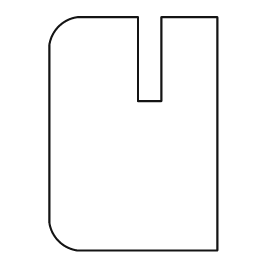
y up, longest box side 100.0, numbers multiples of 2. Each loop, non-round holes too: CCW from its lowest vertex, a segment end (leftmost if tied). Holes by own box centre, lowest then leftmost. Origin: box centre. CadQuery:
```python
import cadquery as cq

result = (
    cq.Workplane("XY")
    .moveTo(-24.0, -50.0)
    .lineTo(36.0, -50.0)
    .lineTo(36.0, 50.0)
    .lineTo(12.0, 50.0)
    .lineTo(12.0, 14.0)
    .lineTo(2.0, 14.0)
    .lineTo(2.0, 50.0)
    .lineTo(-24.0, 50.0)
    .threePointArc((-32.0, 46.0), (-36.0, 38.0))
    .lineTo(-36.0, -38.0)
    .threePointArc((-32.0, -46.0), (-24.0, -50.0))
    .close()
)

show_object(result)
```